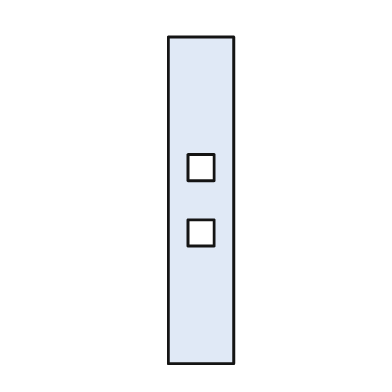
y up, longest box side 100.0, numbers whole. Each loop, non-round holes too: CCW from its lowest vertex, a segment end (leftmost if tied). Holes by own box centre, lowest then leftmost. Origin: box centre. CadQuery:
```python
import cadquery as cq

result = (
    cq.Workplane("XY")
    .moveTo(-10.0, -50.0)
    .lineTo(10.0, -50.0)
    .lineTo(10.0, 50.0)
    .lineTo(-10.0, 50.0)
    .close()
    .moveTo(-4.0, -14.0)
    .lineTo(4.0, -14.0)
    .lineTo(4.0, -6.0)
    .lineTo(-4.0, -6.0)
    .close()
    .moveTo(-4.0, 6.0)
    .lineTo(4.0, 6.0)
    .lineTo(4.0, 14.0)
    .lineTo(-4.0, 14.0)
    .close()
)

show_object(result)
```